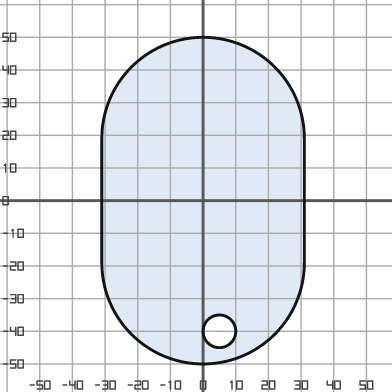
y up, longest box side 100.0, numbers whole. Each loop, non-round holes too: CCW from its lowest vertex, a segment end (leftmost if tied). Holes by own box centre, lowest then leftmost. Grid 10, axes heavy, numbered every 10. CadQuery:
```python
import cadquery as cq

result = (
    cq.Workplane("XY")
    .moveTo(-31.0, -19.0)
    .threePointArc((0.0, -50.0), (31.0, -19.0))
    .lineTo(31.0, 19.0)
    .threePointArc((0.0, 50.0), (-31.0, 19.0))
    .close()
    .moveTo(5.0, -40.0)
    .circle(5.0)
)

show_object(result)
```